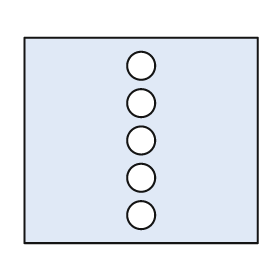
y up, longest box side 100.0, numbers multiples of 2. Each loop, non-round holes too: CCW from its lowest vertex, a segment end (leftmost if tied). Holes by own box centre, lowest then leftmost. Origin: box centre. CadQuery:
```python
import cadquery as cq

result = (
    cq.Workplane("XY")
    .moveTo(-50.0, -44.0)
    .lineTo(50.0, -44.0)
    .lineTo(50.0, 44.0)
    .lineTo(-50.0, 44.0)
    .close()
    .moveTo(0.0, -32.0)
    .circle(6.0)
    .moveTo(0.0, -16.0)
    .circle(6.0)
    .moveTo(0.0, 0.0)
    .circle(6.0)
    .moveTo(0.0, 16.0)
    .circle(6.0)
    .moveTo(0.0, 32.0)
    .circle(6.0)
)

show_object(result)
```